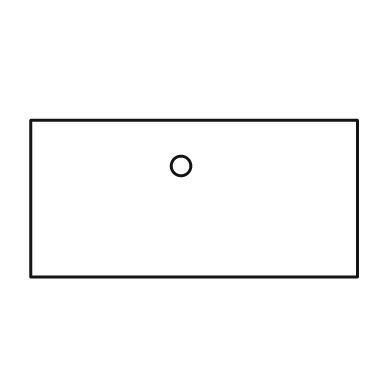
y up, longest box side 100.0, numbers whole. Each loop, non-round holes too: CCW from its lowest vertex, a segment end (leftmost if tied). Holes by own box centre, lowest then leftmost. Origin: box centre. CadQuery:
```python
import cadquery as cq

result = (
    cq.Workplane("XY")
    .moveTo(-50.0, -24.0)
    .lineTo(50.0, -24.0)
    .lineTo(50.0, 24.0)
    .lineTo(-50.0, 24.0)
    .close()
    .moveTo(-4.0, 10.0)
    .circle(3.0)
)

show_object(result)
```